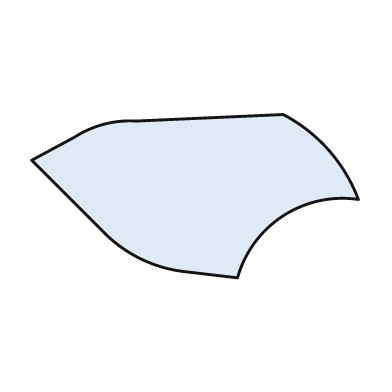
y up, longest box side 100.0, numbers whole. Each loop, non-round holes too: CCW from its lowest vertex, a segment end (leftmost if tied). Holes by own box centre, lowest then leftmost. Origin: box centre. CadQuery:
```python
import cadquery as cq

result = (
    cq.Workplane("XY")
    .moveTo(13.0, -25.0)
    .threePointArc((27.0, -6.0), (50.0, -1.0))
    .threePointArc((41.0, 14.0), (27.0, 25.0))
    .lineTo(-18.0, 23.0)
    .threePointArc((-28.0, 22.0), (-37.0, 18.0))
    .lineTo(-50.0, 11.0)
    .lineTo(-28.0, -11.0)
    .threePointArc((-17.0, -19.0), (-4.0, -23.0))
    .close()
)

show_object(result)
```